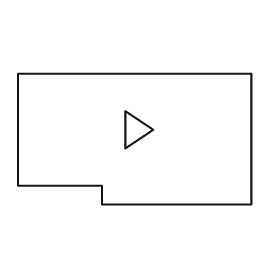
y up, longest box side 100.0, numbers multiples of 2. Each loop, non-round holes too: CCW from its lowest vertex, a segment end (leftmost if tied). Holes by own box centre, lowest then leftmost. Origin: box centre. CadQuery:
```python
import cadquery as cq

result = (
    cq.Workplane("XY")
    .moveTo(-14.0, -28.0)
    .lineTo(50.0, -28.0)
    .lineTo(50.0, 28.0)
    .lineTo(-50.0, 28.0)
    .lineTo(-50.0, -20.0)
    .lineTo(-14.0, -20.0)
    .close()
    .moveTo(-4.0, -4.0)
    .lineTo(8.0, 4.0)
    .lineTo(-4.0, 12.0)
    .close()
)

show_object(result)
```